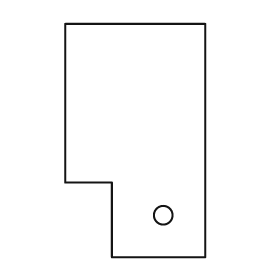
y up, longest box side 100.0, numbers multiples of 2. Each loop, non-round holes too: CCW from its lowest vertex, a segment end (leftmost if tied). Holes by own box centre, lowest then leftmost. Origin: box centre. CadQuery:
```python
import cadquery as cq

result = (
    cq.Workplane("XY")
    .moveTo(-10.0, -50.0)
    .lineTo(30.0, -50.0)
    .lineTo(30.0, 50.0)
    .lineTo(-30.0, 50.0)
    .lineTo(-30.0, -18.0)
    .lineTo(-10.0, -18.0)
    .close()
    .moveTo(12.0, -32.0)
    .circle(4.0)
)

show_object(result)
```